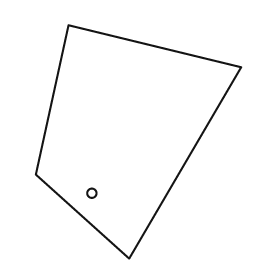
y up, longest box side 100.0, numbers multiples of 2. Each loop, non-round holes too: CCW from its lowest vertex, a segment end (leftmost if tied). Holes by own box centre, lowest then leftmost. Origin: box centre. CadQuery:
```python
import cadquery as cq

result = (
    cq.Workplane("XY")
    .moveTo(-4.0, -50.0)
    .lineTo(44.0, 32.0)
    .lineTo(-30.0, 50.0)
    .lineTo(-44.0, -14.0)
    .close()
    .moveTo(-20.0, -22.0)
    .circle(2.0)
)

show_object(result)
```